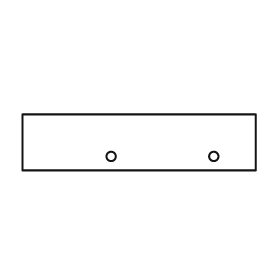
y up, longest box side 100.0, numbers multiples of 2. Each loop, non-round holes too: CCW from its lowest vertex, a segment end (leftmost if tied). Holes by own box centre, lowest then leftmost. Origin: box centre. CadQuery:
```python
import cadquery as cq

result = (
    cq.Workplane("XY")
    .moveTo(-50.0, -12.0)
    .lineTo(50.0, -12.0)
    .lineTo(50.0, 12.0)
    .lineTo(-50.0, 12.0)
    .close()
    .moveTo(-12.0, -6.0)
    .circle(2.0)
    .moveTo(32.0, -6.0)
    .circle(2.0)
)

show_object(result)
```